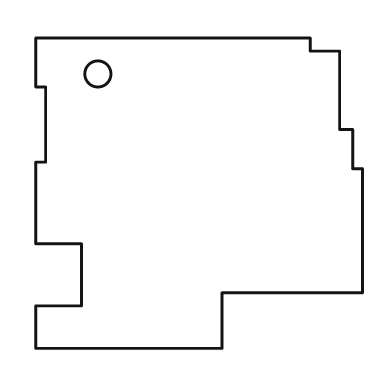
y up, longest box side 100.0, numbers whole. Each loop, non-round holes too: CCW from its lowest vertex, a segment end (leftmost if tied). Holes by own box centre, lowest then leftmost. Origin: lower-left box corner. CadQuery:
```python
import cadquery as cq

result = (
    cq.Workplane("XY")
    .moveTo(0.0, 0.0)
    .lineTo(57.0, 0.0)
    .lineTo(57.0, 17.0)
    .lineTo(100.0, 17.0)
    .lineTo(100.0, 55.0)
    .lineTo(97.0, 55.0)
    .lineTo(97.0, 67.0)
    .lineTo(93.0, 67.0)
    .lineTo(93.0, 91.0)
    .lineTo(84.0, 91.0)
    .lineTo(84.0, 95.0)
    .lineTo(0.0, 95.0)
    .lineTo(0.0, 80.0)
    .lineTo(3.0, 80.0)
    .lineTo(3.0, 57.0)
    .lineTo(0.0, 57.0)
    .lineTo(0.0, 32.0)
    .lineTo(14.0, 32.0)
    .lineTo(14.0, 13.0)
    .lineTo(0.0, 13.0)
    .close()
    .moveTo(19.0, 84.0)
    .circle(4.0)
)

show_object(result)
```